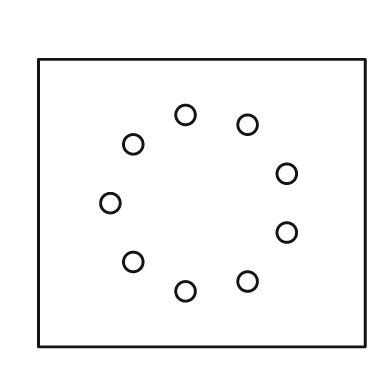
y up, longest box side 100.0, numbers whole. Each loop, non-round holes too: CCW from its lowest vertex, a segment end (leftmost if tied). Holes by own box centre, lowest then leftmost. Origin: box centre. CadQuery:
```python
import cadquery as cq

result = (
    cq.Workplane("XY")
    .moveTo(-50.0, -44.0)
    .lineTo(50.0, -44.0)
    .lineTo(50.0, 44.0)
    .lineTo(-50.0, 44.0)
    .close()
    .moveTo(-5.0, -27.0)
    .circle(3.0)
    .moveTo(14.0, -24.0)
    .circle(3.0)
    .moveTo(-21.0, -18.0)
    .circle(3.0)
    .moveTo(26.0, -9.0)
    .circle(3.0)
    .moveTo(-28.0, 0.0)
    .circle(3.0)
    .moveTo(26.0, 9.0)
    .circle(3.0)
    .moveTo(-21.0, 18.0)
    .circle(3.0)
    .moveTo(14.0, 24.0)
    .circle(3.0)
    .moveTo(-5.0, 27.0)
    .circle(3.0)
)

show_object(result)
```